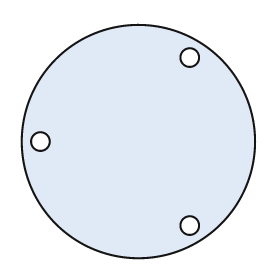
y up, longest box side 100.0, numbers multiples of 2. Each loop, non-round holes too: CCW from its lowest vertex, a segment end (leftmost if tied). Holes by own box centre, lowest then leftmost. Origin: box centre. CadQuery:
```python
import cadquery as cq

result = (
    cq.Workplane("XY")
    .moveTo(0.0, 0.0)
    .circle(50.0)
    .moveTo(22.0, -36.0)
    .circle(4.0)
    .moveTo(-42.0, 0.0)
    .circle(4.0)
    .moveTo(22.0, 36.0)
    .circle(4.0)
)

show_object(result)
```